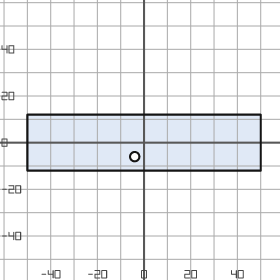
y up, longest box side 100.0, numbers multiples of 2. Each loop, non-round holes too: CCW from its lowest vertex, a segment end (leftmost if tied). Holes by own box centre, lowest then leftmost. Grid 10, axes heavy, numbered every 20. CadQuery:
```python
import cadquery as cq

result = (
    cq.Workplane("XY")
    .moveTo(-50.0, -12.0)
    .lineTo(50.0, -12.0)
    .lineTo(50.0, 12.0)
    .lineTo(-50.0, 12.0)
    .close()
    .moveTo(-4.0, -6.0)
    .circle(2.0)
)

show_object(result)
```